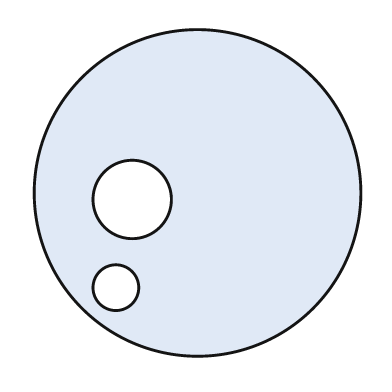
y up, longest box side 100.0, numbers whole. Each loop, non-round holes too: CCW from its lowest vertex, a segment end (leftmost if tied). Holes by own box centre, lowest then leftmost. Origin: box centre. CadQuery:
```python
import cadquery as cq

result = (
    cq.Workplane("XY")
    .moveTo(0.0, 0.0)
    .circle(50.0)
    .moveTo(-25.0, -29.0)
    .circle(7.0)
    .moveTo(-20.0, -2.0)
    .circle(12.0)
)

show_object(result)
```